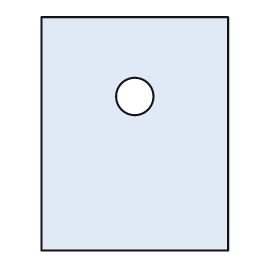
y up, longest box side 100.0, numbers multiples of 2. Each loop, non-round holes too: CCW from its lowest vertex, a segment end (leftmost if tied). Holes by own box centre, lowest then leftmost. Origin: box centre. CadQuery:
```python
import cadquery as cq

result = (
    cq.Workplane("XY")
    .moveTo(-40.0, -50.0)
    .lineTo(40.0, -50.0)
    .lineTo(40.0, 50.0)
    .lineTo(-40.0, 50.0)
    .close()
    .moveTo(0.0, 16.0)
    .circle(8.0)
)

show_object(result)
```